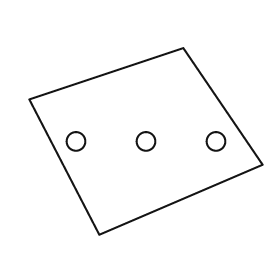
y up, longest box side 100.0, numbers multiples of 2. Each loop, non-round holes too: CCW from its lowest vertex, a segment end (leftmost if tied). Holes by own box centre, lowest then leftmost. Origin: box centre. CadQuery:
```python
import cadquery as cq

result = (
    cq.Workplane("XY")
    .moveTo(-20.0, -40.0)
    .lineTo(50.0, -10.0)
    .lineTo(16.0, 40.0)
    .lineTo(-50.0, 18.0)
    .close()
    .moveTo(-30.0, 0.0)
    .circle(4.0)
    .moveTo(0.0, 0.0)
    .circle(4.0)
    .moveTo(30.0, 0.0)
    .circle(4.0)
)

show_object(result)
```